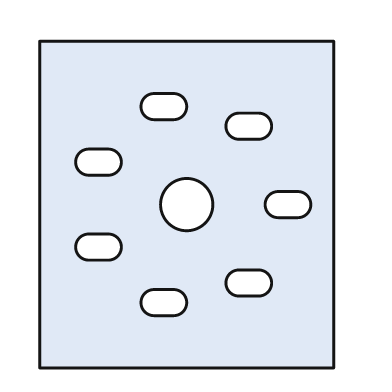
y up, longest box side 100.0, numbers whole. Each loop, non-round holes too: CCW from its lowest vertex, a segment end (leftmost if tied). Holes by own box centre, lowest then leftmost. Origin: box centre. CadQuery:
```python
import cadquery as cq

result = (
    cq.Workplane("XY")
    .moveTo(-45.0, -50.0)
    .lineTo(45.0, -50.0)
    .lineTo(45.0, 50.0)
    .lineTo(-45.0, 50.0)
    .close()
    .moveTo(-10.0, -34.0)
    .lineTo(-4.0, -34.0)
    .threePointArc((0.0, -30.0), (-4.0, -26.0))
    .lineTo(-10.0, -26.0)
    .threePointArc((-14.0, -30.0), (-10.0, -34.0))
    .close()
    .moveTo(16.0, -28.0)
    .lineTo(22.0, -28.0)
    .threePointArc((26.0, -24.0), (22.0, -20.0))
    .lineTo(16.0, -20.0)
    .threePointArc((12.0, -24.0), (16.0, -28.0))
    .close()
    .moveTo(-30.0, -17.0)
    .lineTo(-24.0, -17.0)
    .threePointArc((-20.0, -13.0), (-24.0, -9.0))
    .lineTo(-30.0, -9.0)
    .threePointArc((-34.0, -13.0), (-30.0, -17.0))
    .close()
    .moveTo(0.0, 0.0)
    .circle(8.0)
    .moveTo(28.0, -4.0)
    .lineTo(34.0, -4.0)
    .threePointArc((38.0, 0.0), (34.0, 4.0))
    .lineTo(28.0, 4.0)
    .threePointArc((24.0, 0.0), (28.0, -4.0))
    .close()
    .moveTo(-30.0, 9.0)
    .lineTo(-24.0, 9.0)
    .threePointArc((-20.0, 13.0), (-24.0, 17.0))
    .lineTo(-30.0, 17.0)
    .threePointArc((-34.0, 13.0), (-30.0, 9.0))
    .close()
    .moveTo(16.0, 20.0)
    .lineTo(22.0, 20.0)
    .threePointArc((26.0, 24.0), (22.0, 28.0))
    .lineTo(16.0, 28.0)
    .threePointArc((12.0, 24.0), (16.0, 20.0))
    .close()
    .moveTo(-10.0, 26.0)
    .lineTo(-4.0, 26.0)
    .threePointArc((0.0, 30.0), (-4.0, 34.0))
    .lineTo(-10.0, 34.0)
    .threePointArc((-14.0, 30.0), (-10.0, 26.0))
    .close()
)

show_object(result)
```